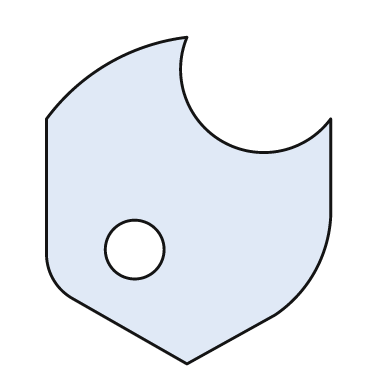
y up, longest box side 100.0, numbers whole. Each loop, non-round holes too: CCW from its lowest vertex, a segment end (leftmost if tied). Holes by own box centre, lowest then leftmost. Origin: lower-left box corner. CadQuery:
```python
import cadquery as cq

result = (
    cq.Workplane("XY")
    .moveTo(43.0, 0.0)
    .lineTo(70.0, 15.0)
    .threePointArc((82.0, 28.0), (87.0, 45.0))
    .lineTo(87.0, 75.0)
    .threePointArc((54.0, 68.0), (43.0, 100.0))
    .threePointArc((19.0, 92.0), (0.0, 75.0))
    .lineTo(0.0, 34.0)
    .threePointArc((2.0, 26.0), (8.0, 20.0))
    .close()
    .moveTo(27.0, 35.0)
    .circle(9.0)
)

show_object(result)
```